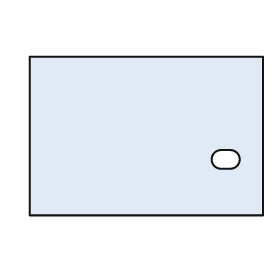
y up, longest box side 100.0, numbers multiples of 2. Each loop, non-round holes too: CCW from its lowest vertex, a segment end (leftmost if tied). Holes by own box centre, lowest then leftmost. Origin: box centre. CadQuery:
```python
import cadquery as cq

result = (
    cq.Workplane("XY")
    .moveTo(-50.0, -34.0)
    .lineTo(50.0, -34.0)
    .lineTo(50.0, 34.0)
    .lineTo(-50.0, 34.0)
    .close()
    .moveTo(32.0, -14.0)
    .lineTo(36.0, -14.0)
    .threePointArc((40.0, -10.0), (36.0, -6.0))
    .lineTo(32.0, -6.0)
    .threePointArc((28.0, -10.0), (32.0, -14.0))
    .close()
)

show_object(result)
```